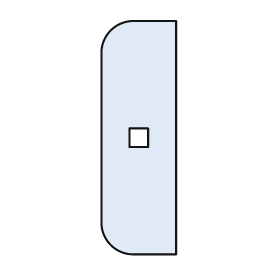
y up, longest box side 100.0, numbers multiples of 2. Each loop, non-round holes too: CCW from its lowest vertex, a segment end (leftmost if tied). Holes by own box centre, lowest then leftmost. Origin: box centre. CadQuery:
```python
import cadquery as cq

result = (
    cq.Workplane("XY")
    .moveTo(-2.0, -50.0)
    .lineTo(16.0, -50.0)
    .lineTo(16.0, 50.0)
    .lineTo(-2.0, 50.0)
    .threePointArc((-12.0, 46.0), (-16.0, 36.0))
    .lineTo(-16.0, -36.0)
    .threePointArc((-12.0, -46.0), (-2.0, -50.0))
    .close()
    .moveTo(-4.0, -4.0)
    .lineTo(4.0, -4.0)
    .lineTo(4.0, 4.0)
    .lineTo(-4.0, 4.0)
    .close()
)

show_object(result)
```